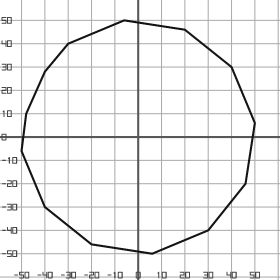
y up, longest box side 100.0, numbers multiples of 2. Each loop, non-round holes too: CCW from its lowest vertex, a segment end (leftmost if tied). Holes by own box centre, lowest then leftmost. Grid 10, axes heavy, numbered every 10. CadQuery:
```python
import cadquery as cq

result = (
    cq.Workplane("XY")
    .moveTo(6.0, -50.0)
    .lineTo(30.0, -40.0)
    .lineTo(46.0, -20.0)
    .lineTo(50.0, 6.0)
    .lineTo(40.0, 30.0)
    .lineTo(20.0, 46.0)
    .lineTo(-6.0, 50.0)
    .lineTo(-30.0, 40.0)
    .lineTo(-40.0, 28.0)
    .lineTo(-48.0, 10.0)
    .lineTo(-50.0, -6.0)
    .lineTo(-40.0, -30.0)
    .lineTo(-20.0, -46.0)
    .close()
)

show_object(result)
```